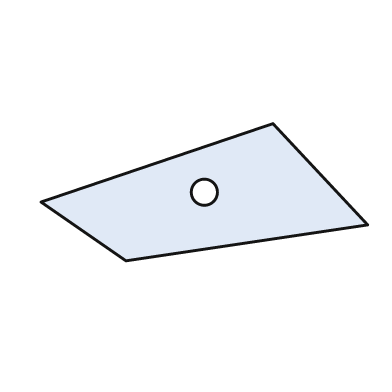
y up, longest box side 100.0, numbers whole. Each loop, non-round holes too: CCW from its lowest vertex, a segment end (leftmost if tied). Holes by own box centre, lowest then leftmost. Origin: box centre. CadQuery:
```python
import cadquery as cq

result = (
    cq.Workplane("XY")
    .moveTo(-24.0, -21.0)
    .lineTo(50.0, -10.0)
    .lineTo(21.0, 21.0)
    .lineTo(-50.0, -3.0)
    .close()
    .moveTo(0.0, 0.0)
    .circle(4.0)
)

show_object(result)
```